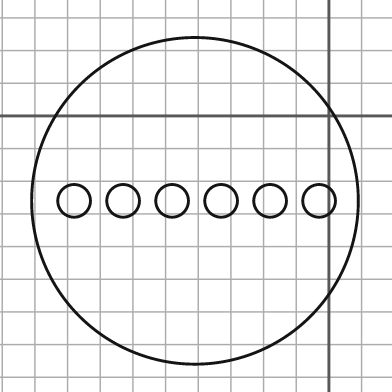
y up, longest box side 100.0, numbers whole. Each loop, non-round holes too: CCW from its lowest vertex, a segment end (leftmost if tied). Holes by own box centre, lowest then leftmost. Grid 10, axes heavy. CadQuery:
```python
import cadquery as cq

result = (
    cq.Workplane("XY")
    .moveTo(-41.0, -26.0)
    .circle(50.0)
    .moveTo(-78.0, -26.0)
    .circle(5.0)
    .moveTo(-63.0, -26.0)
    .circle(5.0)
    .moveTo(-48.0, -26.0)
    .circle(5.0)
    .moveTo(-33.0, -26.0)
    .circle(5.0)
    .moveTo(-18.0, -26.0)
    .circle(5.0)
    .moveTo(-3.0, -26.0)
    .circle(5.0)
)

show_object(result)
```